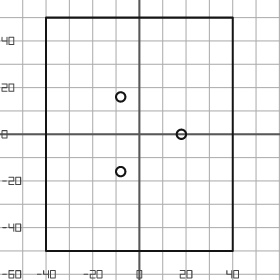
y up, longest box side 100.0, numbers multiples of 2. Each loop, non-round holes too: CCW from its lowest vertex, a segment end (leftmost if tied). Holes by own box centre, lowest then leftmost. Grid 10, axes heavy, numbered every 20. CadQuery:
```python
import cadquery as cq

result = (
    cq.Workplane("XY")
    .moveTo(-40.0, -50.0)
    .lineTo(40.0, -50.0)
    .lineTo(40.0, 50.0)
    .lineTo(-40.0, 50.0)
    .close()
    .moveTo(-8.0, -16.0)
    .circle(2.0)
    .moveTo(18.0, 0.0)
    .circle(2.0)
    .moveTo(-8.0, 16.0)
    .circle(2.0)
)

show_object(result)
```